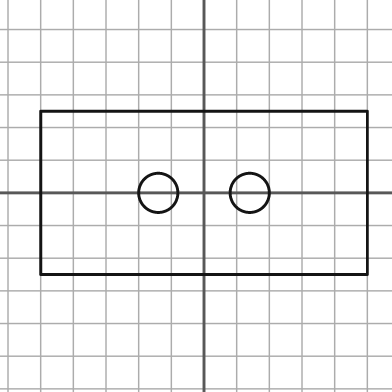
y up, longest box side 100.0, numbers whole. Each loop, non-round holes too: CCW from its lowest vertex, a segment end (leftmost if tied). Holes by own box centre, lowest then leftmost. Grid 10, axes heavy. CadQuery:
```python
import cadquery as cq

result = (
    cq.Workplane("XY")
    .moveTo(-50.0, -25.0)
    .lineTo(50.0, -25.0)
    .lineTo(50.0, 25.0)
    .lineTo(-50.0, 25.0)
    .close()
    .moveTo(-14.0, 0.0)
    .circle(6.0)
    .moveTo(14.0, 0.0)
    .circle(6.0)
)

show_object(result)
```